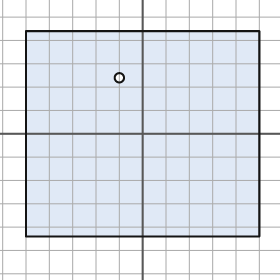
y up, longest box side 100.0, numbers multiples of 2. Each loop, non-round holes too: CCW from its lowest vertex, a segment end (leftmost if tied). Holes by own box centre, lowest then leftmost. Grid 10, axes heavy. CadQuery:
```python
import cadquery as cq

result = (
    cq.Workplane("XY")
    .moveTo(-50.0, -44.0)
    .lineTo(50.0, -44.0)
    .lineTo(50.0, 44.0)
    .lineTo(-50.0, 44.0)
    .close()
    .moveTo(-10.0, 24.0)
    .circle(2.0)
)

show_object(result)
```